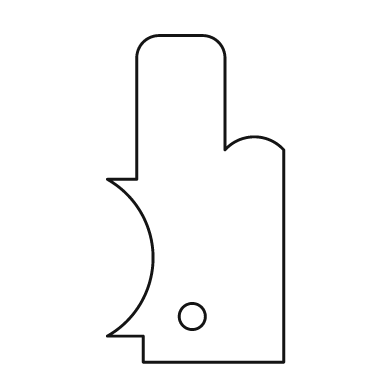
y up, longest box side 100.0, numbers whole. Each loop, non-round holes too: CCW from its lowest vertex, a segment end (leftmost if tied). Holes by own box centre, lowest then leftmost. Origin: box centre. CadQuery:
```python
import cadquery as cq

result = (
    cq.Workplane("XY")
    .moveTo(-16.0, -50.0)
    .lineTo(27.0, -50.0)
    .lineTo(27.0, 15.0)
    .threePointArc((18.0, 19.0), (9.0, 15.0))
    .lineTo(9.0, 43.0)
    .threePointArc((7.0, 48.0), (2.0, 50.0))
    .lineTo(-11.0, 50.0)
    .threePointArc((-16.0, 48.0), (-18.0, 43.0))
    .lineTo(-18.0, 6.0)
    .lineTo(-27.0, 6.0)
    .threePointArc((-13.0, -18.0), (-27.0, -42.0))
    .lineTo(-16.0, -42.0)
    .close()
    .moveTo(-1.0, -36.0)
    .circle(4.0)
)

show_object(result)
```